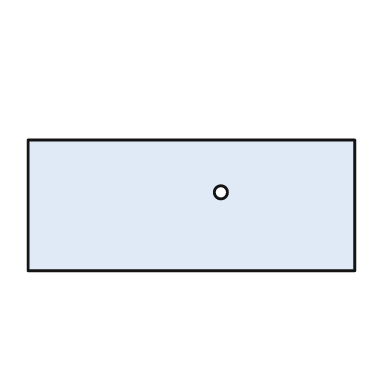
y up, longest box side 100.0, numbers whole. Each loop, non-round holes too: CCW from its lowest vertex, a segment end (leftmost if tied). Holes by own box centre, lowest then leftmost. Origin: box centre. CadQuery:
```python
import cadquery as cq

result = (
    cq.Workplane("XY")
    .moveTo(-50.0, -20.0)
    .lineTo(50.0, -20.0)
    .lineTo(50.0, 20.0)
    .lineTo(-50.0, 20.0)
    .close()
    .moveTo(9.0, 4.0)
    .circle(2.0)
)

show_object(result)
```